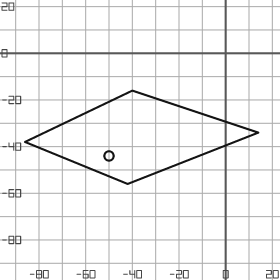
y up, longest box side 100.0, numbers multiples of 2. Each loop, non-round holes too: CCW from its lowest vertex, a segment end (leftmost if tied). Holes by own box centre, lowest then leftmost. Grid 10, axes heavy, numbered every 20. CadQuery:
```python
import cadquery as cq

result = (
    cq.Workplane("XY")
    .moveTo(-42.0, -56.0)
    .lineTo(14.0, -34.0)
    .lineTo(-40.0, -16.0)
    .lineTo(-86.0, -38.0)
    .close()
    .moveTo(-50.0, -44.0)
    .circle(2.0)
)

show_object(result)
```